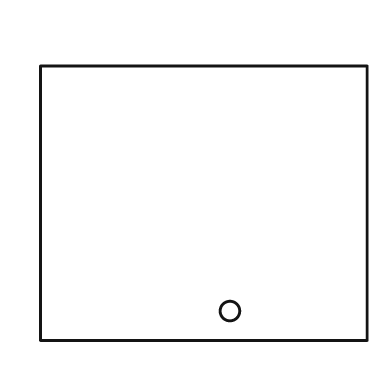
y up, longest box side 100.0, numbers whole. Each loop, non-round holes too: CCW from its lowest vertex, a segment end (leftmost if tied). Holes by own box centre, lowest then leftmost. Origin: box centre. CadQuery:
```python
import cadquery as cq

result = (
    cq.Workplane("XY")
    .moveTo(-50.0, -42.0)
    .lineTo(50.0, -42.0)
    .lineTo(50.0, 42.0)
    .lineTo(-50.0, 42.0)
    .close()
    .moveTo(8.0, -33.0)
    .circle(3.0)
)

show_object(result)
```